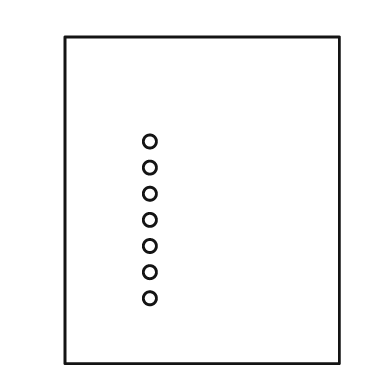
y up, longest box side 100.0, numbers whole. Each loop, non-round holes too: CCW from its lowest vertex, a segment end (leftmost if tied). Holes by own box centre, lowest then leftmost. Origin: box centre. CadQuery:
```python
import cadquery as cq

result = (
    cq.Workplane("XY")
    .moveTo(-42.0, -50.0)
    .lineTo(42.0, -50.0)
    .lineTo(42.0, 50.0)
    .lineTo(-42.0, 50.0)
    .close()
    .moveTo(-16.0, -30.0)
    .circle(2.0)
    .moveTo(-16.0, -22.0)
    .circle(2.0)
    .moveTo(-16.0, -14.0)
    .circle(2.0)
    .moveTo(-16.0, -6.0)
    .circle(2.0)
    .moveTo(-16.0, 2.0)
    .circle(2.0)
    .moveTo(-16.0, 10.0)
    .circle(2.0)
    .moveTo(-16.0, 18.0)
    .circle(2.0)
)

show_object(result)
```